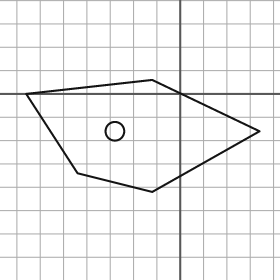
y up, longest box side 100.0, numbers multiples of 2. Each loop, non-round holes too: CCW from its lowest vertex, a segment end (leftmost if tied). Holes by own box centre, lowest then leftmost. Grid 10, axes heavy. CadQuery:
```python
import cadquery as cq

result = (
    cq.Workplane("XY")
    .moveTo(-12.0, -42.0)
    .lineTo(34.0, -16.0)
    .lineTo(-12.0, 6.0)
    .lineTo(-66.0, 0.0)
    .lineTo(-44.0, -34.0)
    .close()
    .moveTo(-28.0, -16.0)
    .circle(4.0)
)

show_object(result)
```